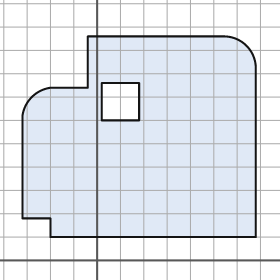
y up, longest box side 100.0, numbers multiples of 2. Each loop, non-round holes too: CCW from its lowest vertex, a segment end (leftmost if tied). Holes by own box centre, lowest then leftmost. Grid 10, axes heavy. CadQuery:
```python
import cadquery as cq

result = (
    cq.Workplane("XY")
    .moveTo(-20.0, 10.0)
    .lineTo(68.0, 10.0)
    .lineTo(68.0, 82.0)
    .threePointArc((64.0, 92.0), (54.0, 96.0))
    .lineTo(-4.0, 96.0)
    .lineTo(-4.0, 74.0)
    .lineTo(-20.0, 74.0)
    .threePointArc((-28.0, 70.0), (-32.0, 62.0))
    .lineTo(-32.0, 18.0)
    .lineTo(-20.0, 18.0)
    .close()
    .moveTo(2.0, 60.0)
    .lineTo(18.0, 60.0)
    .lineTo(18.0, 76.0)
    .lineTo(2.0, 76.0)
    .close()
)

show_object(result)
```